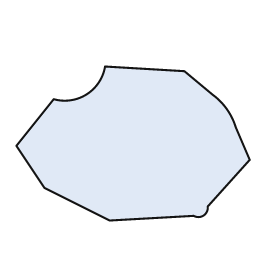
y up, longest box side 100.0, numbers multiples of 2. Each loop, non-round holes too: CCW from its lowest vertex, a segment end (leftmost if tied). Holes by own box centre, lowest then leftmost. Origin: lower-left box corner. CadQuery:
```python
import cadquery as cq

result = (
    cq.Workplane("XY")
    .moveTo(40.0, 0.0)
    .lineTo(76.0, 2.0)
    .threePointArc((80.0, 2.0), (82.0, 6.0))
    .lineTo(100.0, 26.0)
    .lineTo(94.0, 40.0)
    .threePointArc((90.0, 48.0), (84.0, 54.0))
    .lineTo(72.0, 64.0)
    .lineTo(38.0, 66.0)
    .threePointArc((30.0, 54.0), (16.0, 52.0))
    .lineTo(0.0, 32.0)
    .lineTo(12.0, 14.0)
    .close()
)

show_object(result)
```